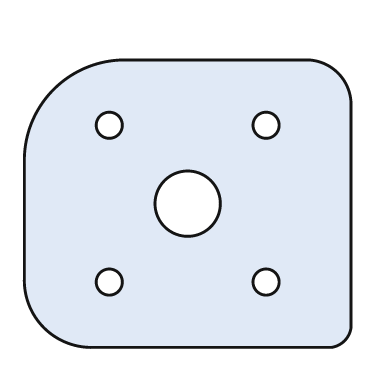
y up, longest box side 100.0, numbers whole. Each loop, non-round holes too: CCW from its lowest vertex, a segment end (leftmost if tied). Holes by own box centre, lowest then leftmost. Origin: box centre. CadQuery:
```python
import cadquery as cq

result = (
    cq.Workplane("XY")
    .moveTo(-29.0, -44.0)
    .lineTo(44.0, -44.0)
    .threePointArc((48.0, -42.0), (50.0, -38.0))
    .lineTo(50.0, 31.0)
    .threePointArc((46.0, 40.0), (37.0, 44.0))
    .lineTo(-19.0, 44.0)
    .threePointArc((-41.0, 35.0), (-50.0, 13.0))
    .lineTo(-50.0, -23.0)
    .threePointArc((-44.0, -38.0), (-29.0, -44.0))
    .close()
    .moveTo(-24.0, -24.0)
    .circle(4.0)
    .moveTo(24.0, -24.0)
    .circle(4.0)
    .moveTo(0.0, 0.0)
    .circle(10.0)
    .moveTo(-24.0, 24.0)
    .circle(4.0)
    .moveTo(24.0, 24.0)
    .circle(4.0)
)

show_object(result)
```